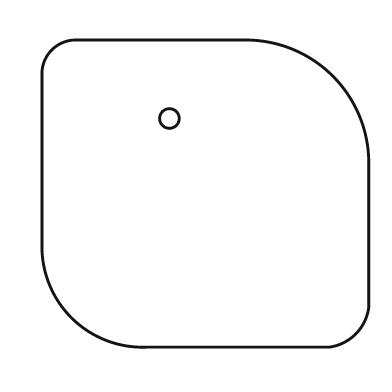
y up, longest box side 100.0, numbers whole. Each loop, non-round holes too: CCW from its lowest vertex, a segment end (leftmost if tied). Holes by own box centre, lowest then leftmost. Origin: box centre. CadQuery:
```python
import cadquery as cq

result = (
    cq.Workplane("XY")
    .moveTo(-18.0, -47.0)
    .lineTo(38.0, -47.0)
    .threePointArc((46.0, -43.0), (50.0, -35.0))
    .lineTo(50.0, 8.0)
    .threePointArc((39.0, 36.0), (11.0, 47.0))
    .lineTo(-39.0, 47.0)
    .threePointArc((-47.0, 44.0), (-50.0, 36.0))
    .lineTo(-50.0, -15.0)
    .threePointArc((-41.0, -38.0), (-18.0, -47.0))
    .close()
    .moveTo(-11.0, 23.0)
    .circle(3.0)
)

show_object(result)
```